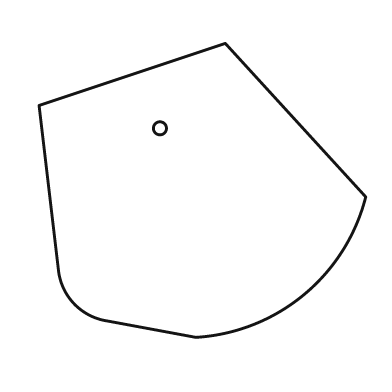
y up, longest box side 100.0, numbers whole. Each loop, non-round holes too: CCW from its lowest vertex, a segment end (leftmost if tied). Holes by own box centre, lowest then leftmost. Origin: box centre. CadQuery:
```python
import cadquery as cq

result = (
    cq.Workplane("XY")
    .moveTo(-2.0, -45.0)
    .threePointArc((31.0, -32.0), (50.0, -2.0))
    .lineTo(7.0, 45.0)
    .lineTo(-50.0, 26.0)
    .lineTo(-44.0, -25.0)
    .threePointArc((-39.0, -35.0), (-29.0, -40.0))
    .close()
    .moveTo(-13.0, 19.0)
    .circle(2.0)
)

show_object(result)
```